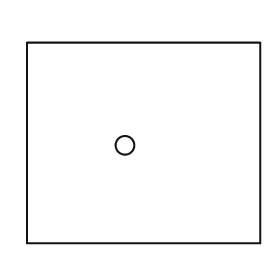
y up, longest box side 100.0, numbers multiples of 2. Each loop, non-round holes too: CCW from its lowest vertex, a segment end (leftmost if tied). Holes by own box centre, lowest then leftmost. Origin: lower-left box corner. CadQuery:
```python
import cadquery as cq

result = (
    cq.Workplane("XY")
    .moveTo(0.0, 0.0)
    .lineTo(100.0, 0.0)
    .lineTo(100.0, 86.0)
    .lineTo(0.0, 86.0)
    .close()
    .moveTo(42.0, 42.0)
    .circle(4.0)
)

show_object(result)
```